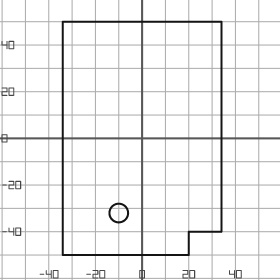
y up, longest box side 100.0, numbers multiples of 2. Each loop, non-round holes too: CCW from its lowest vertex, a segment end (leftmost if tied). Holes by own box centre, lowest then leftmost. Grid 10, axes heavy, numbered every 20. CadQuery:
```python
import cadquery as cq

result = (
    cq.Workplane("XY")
    .moveTo(-34.0, -50.0)
    .lineTo(20.0, -50.0)
    .lineTo(20.0, -40.0)
    .lineTo(34.0, -40.0)
    .lineTo(34.0, 50.0)
    .lineTo(-34.0, 50.0)
    .close()
    .moveTo(-10.0, -32.0)
    .circle(4.0)
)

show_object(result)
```